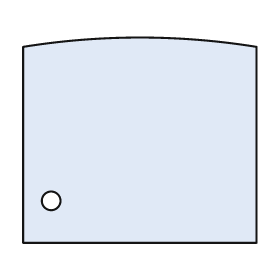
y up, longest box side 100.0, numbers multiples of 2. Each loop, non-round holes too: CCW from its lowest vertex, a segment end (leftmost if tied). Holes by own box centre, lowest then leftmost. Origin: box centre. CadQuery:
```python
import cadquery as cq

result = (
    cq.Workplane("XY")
    .moveTo(-50.0, -44.0)
    .lineTo(50.0, -44.0)
    .lineTo(50.0, 40.0)
    .threePointArc((0.0, 44.0), (-50.0, 40.0))
    .close()
    .moveTo(-38.0, -26.0)
    .circle(4.0)
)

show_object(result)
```